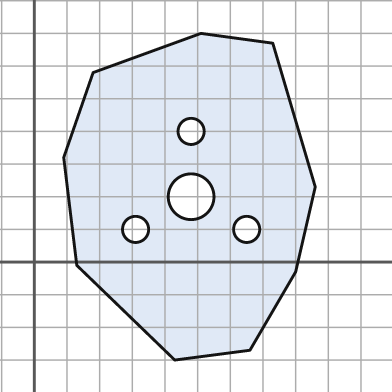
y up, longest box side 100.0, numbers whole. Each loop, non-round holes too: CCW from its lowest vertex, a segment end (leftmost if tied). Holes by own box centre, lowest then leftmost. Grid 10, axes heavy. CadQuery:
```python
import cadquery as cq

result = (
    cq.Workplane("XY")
    .moveTo(43.0, -30.0)
    .lineTo(66.0, -27.0)
    .lineTo(80.0, -3.0)
    .lineTo(86.0, 23.0)
    .lineTo(73.0, 67.0)
    .lineTo(51.0, 70.0)
    .lineTo(18.0, 58.0)
    .lineTo(9.0, 32.0)
    .lineTo(13.0, -1.0)
    .close()
    .moveTo(31.0, 10.0)
    .circle(4.0)
    .moveTo(65.0, 10.0)
    .circle(4.0)
    .moveTo(48.0, 20.0)
    .circle(7.0)
    .moveTo(48.0, 40.0)
    .circle(4.0)
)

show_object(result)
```